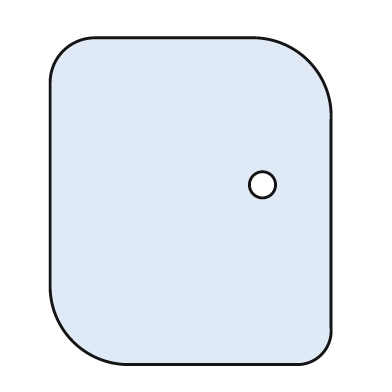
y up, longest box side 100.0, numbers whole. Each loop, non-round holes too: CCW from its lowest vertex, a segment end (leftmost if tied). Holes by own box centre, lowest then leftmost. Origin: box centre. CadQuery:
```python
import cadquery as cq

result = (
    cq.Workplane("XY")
    .moveTo(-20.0, -50.0)
    .lineTo(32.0, -50.0)
    .threePointArc((40.0, -47.0), (43.0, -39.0))
    .lineTo(43.0, 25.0)
    .threePointArc((36.0, 43.0), (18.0, 50.0))
    .lineTo(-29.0, 50.0)
    .threePointArc((-39.0, 46.0), (-43.0, 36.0))
    .lineTo(-43.0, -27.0)
    .threePointArc((-36.0, -43.0), (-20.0, -50.0))
    .close()
    .moveTo(22.0, 5.0)
    .circle(4.0)
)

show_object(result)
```